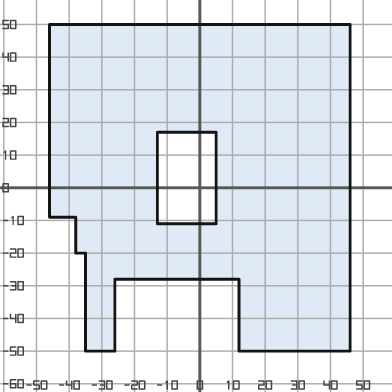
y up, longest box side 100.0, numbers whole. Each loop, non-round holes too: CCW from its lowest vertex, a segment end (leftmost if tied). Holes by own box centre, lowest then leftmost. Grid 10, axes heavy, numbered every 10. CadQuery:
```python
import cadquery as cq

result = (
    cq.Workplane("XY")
    .moveTo(-35.0, -50.0)
    .lineTo(-26.0, -50.0)
    .lineTo(-26.0, -28.0)
    .lineTo(12.0, -28.0)
    .lineTo(12.0, -50.0)
    .lineTo(46.0, -50.0)
    .lineTo(46.0, 50.0)
    .lineTo(-46.0, 50.0)
    .lineTo(-46.0, -9.0)
    .lineTo(-38.0, -9.0)
    .lineTo(-38.0, -20.0)
    .lineTo(-35.0, -20.0)
    .close()
    .moveTo(-13.0, -11.0)
    .lineTo(5.0, -11.0)
    .lineTo(5.0, 17.0)
    .lineTo(-13.0, 17.0)
    .close()
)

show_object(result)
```